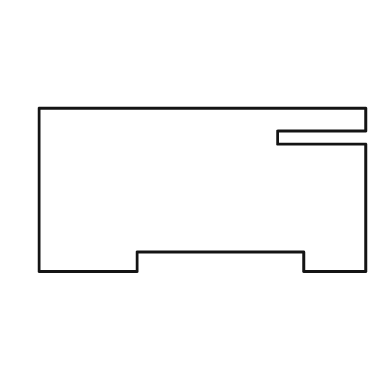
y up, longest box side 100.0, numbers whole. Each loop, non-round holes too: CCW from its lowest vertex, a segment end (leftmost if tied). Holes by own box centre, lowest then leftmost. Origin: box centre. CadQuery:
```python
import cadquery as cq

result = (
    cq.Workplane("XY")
    .moveTo(-50.0, -25.0)
    .lineTo(-20.0, -25.0)
    .lineTo(-20.0, -19.0)
    .lineTo(31.0, -19.0)
    .lineTo(31.0, -25.0)
    .lineTo(50.0, -25.0)
    .lineTo(50.0, 14.0)
    .lineTo(23.0, 14.0)
    .lineTo(23.0, 18.0)
    .lineTo(50.0, 18.0)
    .lineTo(50.0, 25.0)
    .lineTo(-50.0, 25.0)
    .close()
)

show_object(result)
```